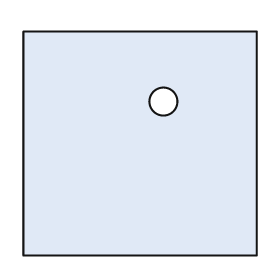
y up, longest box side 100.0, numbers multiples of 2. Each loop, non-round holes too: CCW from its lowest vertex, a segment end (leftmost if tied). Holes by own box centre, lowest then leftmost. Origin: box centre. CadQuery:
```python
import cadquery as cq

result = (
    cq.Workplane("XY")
    .moveTo(-50.0, -48.0)
    .lineTo(50.0, -48.0)
    .lineTo(50.0, 48.0)
    .lineTo(-50.0, 48.0)
    .close()
    .moveTo(10.0, 18.0)
    .circle(6.0)
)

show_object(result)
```